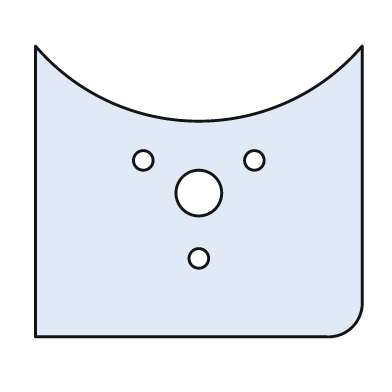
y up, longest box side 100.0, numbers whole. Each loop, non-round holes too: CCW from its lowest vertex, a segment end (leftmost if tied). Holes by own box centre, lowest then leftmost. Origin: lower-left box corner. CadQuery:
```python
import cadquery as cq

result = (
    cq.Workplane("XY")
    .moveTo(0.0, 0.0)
    .lineTo(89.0, 0.0)
    .threePointArc((97.0, 3.0), (100.0, 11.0))
    .lineTo(100.0, 89.0)
    .threePointArc((50.0, 66.0), (0.0, 89.0))
    .close()
    .moveTo(50.0, 24.0)
    .circle(3.0)
    .moveTo(50.0, 44.0)
    .circle(7.0)
    .moveTo(33.0, 54.0)
    .circle(3.0)
    .moveTo(67.0, 54.0)
    .circle(3.0)
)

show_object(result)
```